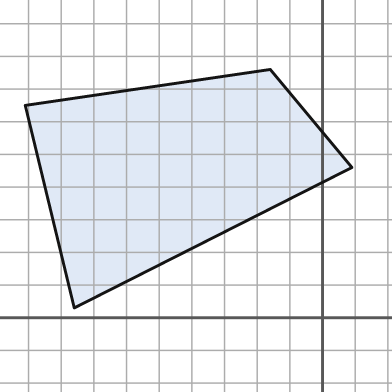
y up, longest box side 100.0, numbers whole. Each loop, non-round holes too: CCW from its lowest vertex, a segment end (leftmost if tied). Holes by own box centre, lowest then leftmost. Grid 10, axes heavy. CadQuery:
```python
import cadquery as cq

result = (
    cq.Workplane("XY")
    .moveTo(-76.0, 3.0)
    .lineTo(9.0, 46.0)
    .lineTo(-16.0, 76.0)
    .lineTo(-91.0, 65.0)
    .close()
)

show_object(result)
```